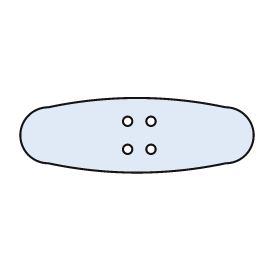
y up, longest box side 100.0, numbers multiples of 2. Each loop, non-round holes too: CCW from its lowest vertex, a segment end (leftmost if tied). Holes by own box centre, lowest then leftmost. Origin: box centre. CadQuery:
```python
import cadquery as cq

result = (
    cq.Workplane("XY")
    .moveTo(-38.0, -12.0)
    .threePointArc((0.0, -16.0), (38.0, -12.0))
    .threePointArc((50.0, 0.0), (38.0, 12.0))
    .threePointArc((0.0, 16.0), (-38.0, 12.0))
    .threePointArc((-50.0, 0.0), (-38.0, -12.0))
    .close()
    .moveTo(-4.0, -6.0)
    .circle(2.0)
    .moveTo(6.0, -6.0)
    .circle(2.0)
    .moveTo(-4.0, 6.0)
    .circle(2.0)
    .moveTo(6.0, 6.0)
    .circle(2.0)
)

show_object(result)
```